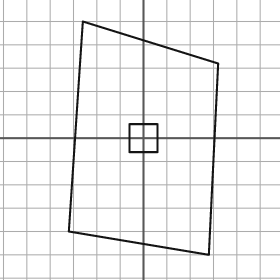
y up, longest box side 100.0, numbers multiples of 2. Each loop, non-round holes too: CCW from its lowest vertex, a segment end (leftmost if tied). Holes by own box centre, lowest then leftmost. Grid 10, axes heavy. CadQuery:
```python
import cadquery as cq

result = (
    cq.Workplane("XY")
    .moveTo(28.0, -50.0)
    .lineTo(32.0, 32.0)
    .lineTo(-26.0, 50.0)
    .lineTo(-32.0, -40.0)
    .close()
    .moveTo(-6.0, -6.0)
    .lineTo(6.0, -6.0)
    .lineTo(6.0, 6.0)
    .lineTo(-6.0, 6.0)
    .close()
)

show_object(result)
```